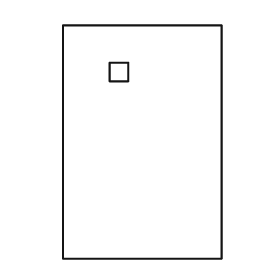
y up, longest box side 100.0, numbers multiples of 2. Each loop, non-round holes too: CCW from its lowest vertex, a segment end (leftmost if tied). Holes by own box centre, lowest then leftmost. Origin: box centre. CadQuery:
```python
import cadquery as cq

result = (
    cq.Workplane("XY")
    .moveTo(-34.0, -50.0)
    .lineTo(34.0, -50.0)
    .lineTo(34.0, 50.0)
    .lineTo(-34.0, 50.0)
    .close()
    .moveTo(-14.0, 26.0)
    .lineTo(-6.0, 26.0)
    .lineTo(-6.0, 34.0)
    .lineTo(-14.0, 34.0)
    .close()
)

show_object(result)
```